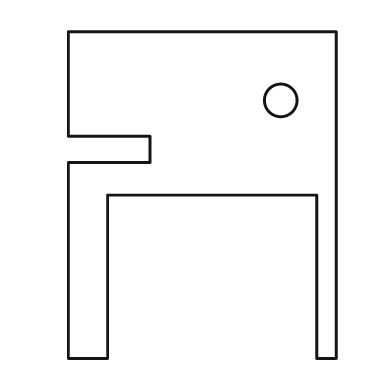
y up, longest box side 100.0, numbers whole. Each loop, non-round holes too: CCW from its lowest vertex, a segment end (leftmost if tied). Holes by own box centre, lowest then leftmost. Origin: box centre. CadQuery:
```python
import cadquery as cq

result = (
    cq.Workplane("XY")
    .moveTo(-41.0, -50.0)
    .lineTo(-29.0, -50.0)
    .lineTo(-29.0, 0.0)
    .lineTo(35.0, 0.0)
    .lineTo(35.0, -50.0)
    .lineTo(41.0, -50.0)
    .lineTo(41.0, 50.0)
    .lineTo(-41.0, 50.0)
    .lineTo(-41.0, 18.0)
    .lineTo(-16.0, 18.0)
    .lineTo(-16.0, 10.0)
    .lineTo(-41.0, 10.0)
    .close()
    .moveTo(24.0, 29.0)
    .circle(5.0)
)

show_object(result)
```